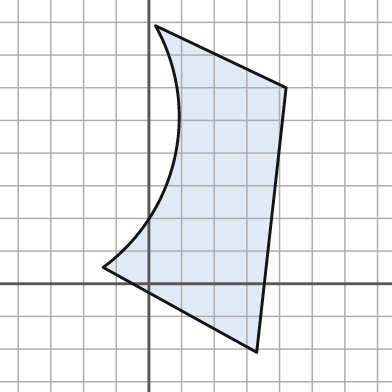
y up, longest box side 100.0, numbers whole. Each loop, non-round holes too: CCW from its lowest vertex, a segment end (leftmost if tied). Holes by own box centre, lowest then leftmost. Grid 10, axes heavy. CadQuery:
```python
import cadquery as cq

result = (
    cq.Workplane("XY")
    .moveTo(33.0, -21.0)
    .lineTo(42.0, 60.0)
    .lineTo(2.0, 79.0)
    .threePointArc((8.0, 39.0), (-14.0, 5.0))
    .close()
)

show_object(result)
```